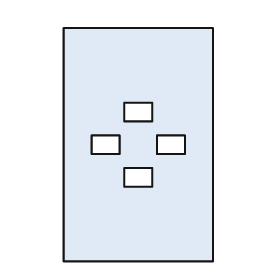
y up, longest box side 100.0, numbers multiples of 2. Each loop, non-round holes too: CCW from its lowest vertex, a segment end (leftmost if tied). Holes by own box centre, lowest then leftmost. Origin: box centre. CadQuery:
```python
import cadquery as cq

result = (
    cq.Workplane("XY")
    .moveTo(-32.0, -50.0)
    .lineTo(32.0, -50.0)
    .lineTo(32.0, 50.0)
    .lineTo(-32.0, 50.0)
    .close()
    .moveTo(-6.0, -18.0)
    .lineTo(6.0, -18.0)
    .lineTo(6.0, -10.0)
    .lineTo(-6.0, -10.0)
    .close()
    .moveTo(-20.0, -4.0)
    .lineTo(-8.0, -4.0)
    .lineTo(-8.0, 4.0)
    .lineTo(-20.0, 4.0)
    .close()
    .moveTo(8.0, -4.0)
    .lineTo(20.0, -4.0)
    .lineTo(20.0, 4.0)
    .lineTo(8.0, 4.0)
    .close()
    .moveTo(-6.0, 10.0)
    .lineTo(6.0, 10.0)
    .lineTo(6.0, 18.0)
    .lineTo(-6.0, 18.0)
    .close()
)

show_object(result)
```